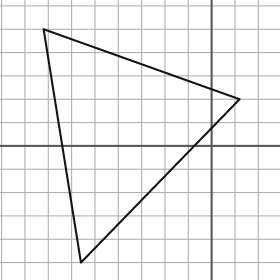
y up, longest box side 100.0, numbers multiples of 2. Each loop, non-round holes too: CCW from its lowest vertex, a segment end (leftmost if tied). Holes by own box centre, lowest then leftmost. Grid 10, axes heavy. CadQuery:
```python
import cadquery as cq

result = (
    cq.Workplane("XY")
    .moveTo(-56.0, -50.0)
    .lineTo(12.0, 20.0)
    .lineTo(-72.0, 50.0)
    .close()
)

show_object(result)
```